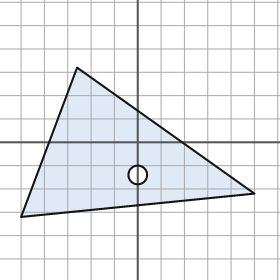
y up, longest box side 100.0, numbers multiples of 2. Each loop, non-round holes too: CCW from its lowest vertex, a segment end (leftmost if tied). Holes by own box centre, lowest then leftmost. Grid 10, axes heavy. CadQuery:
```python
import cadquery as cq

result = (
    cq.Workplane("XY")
    .moveTo(-50.0, -32.0)
    .lineTo(50.0, -22.0)
    .lineTo(-26.0, 32.0)
    .close()
    .moveTo(0.0, -14.0)
    .circle(4.0)
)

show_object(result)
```